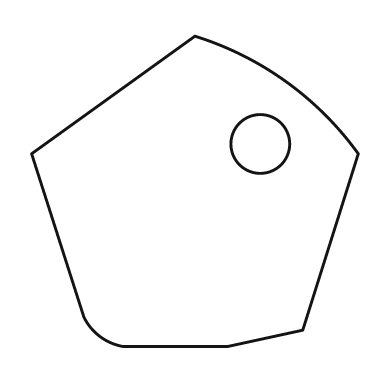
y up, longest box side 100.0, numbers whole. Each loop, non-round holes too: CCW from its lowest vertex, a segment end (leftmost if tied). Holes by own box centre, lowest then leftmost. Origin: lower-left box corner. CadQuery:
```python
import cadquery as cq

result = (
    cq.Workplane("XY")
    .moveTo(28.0, 0.0)
    .lineTo(60.0, 0.0)
    .lineTo(83.0, 5.0)
    .lineTo(100.0, 59.0)
    .threePointArc((78.0, 81.0), (50.0, 95.0))
    .lineTo(0.0, 59.0)
    .lineTo(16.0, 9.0)
    .threePointArc((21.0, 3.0), (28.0, 0.0))
    .close()
    .moveTo(70.0, 62.0)
    .circle(9.0)
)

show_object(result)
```